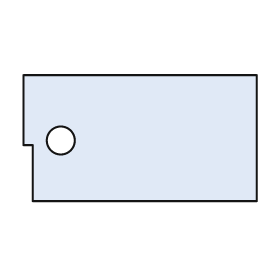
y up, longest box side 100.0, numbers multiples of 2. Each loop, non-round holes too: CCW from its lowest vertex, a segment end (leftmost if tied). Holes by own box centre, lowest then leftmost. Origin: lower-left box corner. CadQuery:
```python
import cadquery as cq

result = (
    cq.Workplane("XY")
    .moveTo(4.0, 0.0)
    .lineTo(100.0, 0.0)
    .lineTo(100.0, 54.0)
    .lineTo(0.0, 54.0)
    .lineTo(0.0, 24.0)
    .lineTo(4.0, 24.0)
    .close()
    .moveTo(16.0, 26.0)
    .circle(6.0)
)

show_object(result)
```